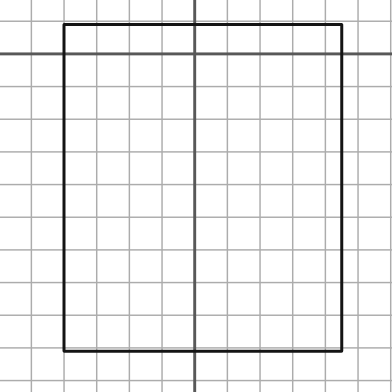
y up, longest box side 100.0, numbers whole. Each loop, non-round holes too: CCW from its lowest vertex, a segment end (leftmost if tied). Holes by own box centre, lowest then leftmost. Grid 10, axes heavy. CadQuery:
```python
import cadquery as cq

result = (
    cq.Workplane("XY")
    .moveTo(-40.0, -91.0)
    .lineTo(45.0, -91.0)
    .lineTo(45.0, 9.0)
    .lineTo(-40.0, 9.0)
    .close()
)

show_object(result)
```